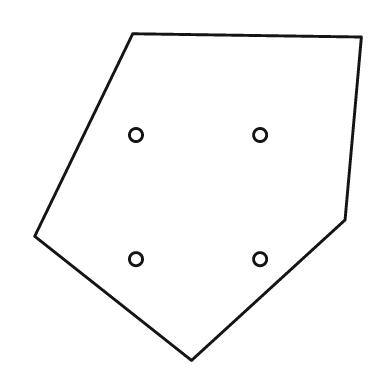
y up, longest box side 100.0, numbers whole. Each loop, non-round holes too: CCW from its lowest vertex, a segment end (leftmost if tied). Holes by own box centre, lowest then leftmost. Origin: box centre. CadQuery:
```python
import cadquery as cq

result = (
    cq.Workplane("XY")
    .moveTo(-2.0, -50.0)
    .lineTo(45.0, -7.0)
    .lineTo(50.0, 49.0)
    .lineTo(-20.0, 50.0)
    .lineTo(-50.0, -12.0)
    .close()
    .moveTo(-19.0, -19.0)
    .circle(2.0)
    .moveTo(19.0, -19.0)
    .circle(2.0)
    .moveTo(-19.0, 19.0)
    .circle(2.0)
    .moveTo(19.0, 19.0)
    .circle(2.0)
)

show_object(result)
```